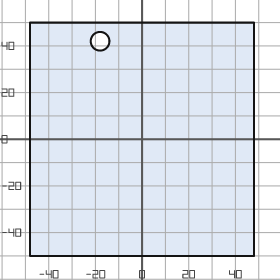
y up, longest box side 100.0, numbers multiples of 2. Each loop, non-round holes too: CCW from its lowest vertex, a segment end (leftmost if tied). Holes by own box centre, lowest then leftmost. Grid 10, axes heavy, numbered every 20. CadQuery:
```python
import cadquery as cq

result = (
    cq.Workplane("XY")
    .moveTo(-48.0, -50.0)
    .lineTo(48.0, -50.0)
    .lineTo(48.0, 50.0)
    .lineTo(-48.0, 50.0)
    .close()
    .moveTo(-18.0, 42.0)
    .circle(4.0)
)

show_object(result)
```